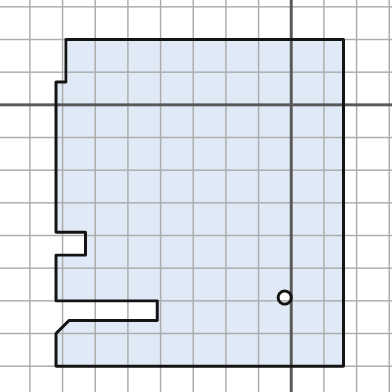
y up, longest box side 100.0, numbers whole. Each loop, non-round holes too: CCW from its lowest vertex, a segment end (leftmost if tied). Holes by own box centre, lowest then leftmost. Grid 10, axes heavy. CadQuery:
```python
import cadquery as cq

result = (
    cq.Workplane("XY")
    .moveTo(-72.0, -80.0)
    .lineTo(16.0, -80.0)
    .lineTo(16.0, 20.0)
    .lineTo(-69.0, 20.0)
    .lineTo(-69.0, 7.0)
    .lineTo(-72.0, 7.0)
    .lineTo(-72.0, -39.0)
    .lineTo(-63.0, -39.0)
    .lineTo(-63.0, -46.0)
    .lineTo(-72.0, -46.0)
    .lineTo(-72.0, -60.0)
    .lineTo(-41.0, -60.0)
    .lineTo(-41.0, -66.0)
    .lineTo(-68.0, -66.0)
    .lineTo(-72.0, -70.0)
    .close()
    .moveTo(-2.0, -59.0)
    .circle(2.0)
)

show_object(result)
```